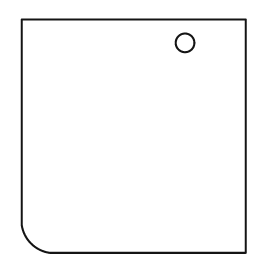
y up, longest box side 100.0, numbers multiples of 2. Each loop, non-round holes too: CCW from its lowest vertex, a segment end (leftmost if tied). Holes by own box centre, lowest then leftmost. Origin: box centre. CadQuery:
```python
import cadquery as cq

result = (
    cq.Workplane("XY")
    .moveTo(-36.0, -50.0)
    .lineTo(48.0, -50.0)
    .lineTo(48.0, 50.0)
    .lineTo(-48.0, 50.0)
    .lineTo(-48.0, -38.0)
    .threePointArc((-44.0, -46.0), (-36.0, -50.0))
    .close()
    .moveTo(22.0, 40.0)
    .circle(4.0)
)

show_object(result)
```